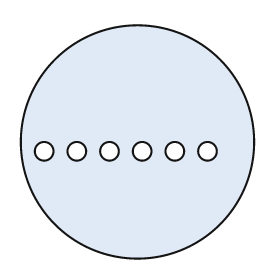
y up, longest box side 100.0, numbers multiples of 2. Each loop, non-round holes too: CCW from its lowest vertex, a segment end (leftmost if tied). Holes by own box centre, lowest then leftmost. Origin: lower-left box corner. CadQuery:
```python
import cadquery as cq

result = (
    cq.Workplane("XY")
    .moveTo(50.0, 50.0)
    .circle(50.0)
    .moveTo(10.0, 46.0)
    .circle(4.0)
    .moveTo(24.0, 46.0)
    .circle(4.0)
    .moveTo(38.0, 46.0)
    .circle(4.0)
    .moveTo(52.0, 46.0)
    .circle(4.0)
    .moveTo(66.0, 46.0)
    .circle(4.0)
    .moveTo(80.0, 46.0)
    .circle(4.0)
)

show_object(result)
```